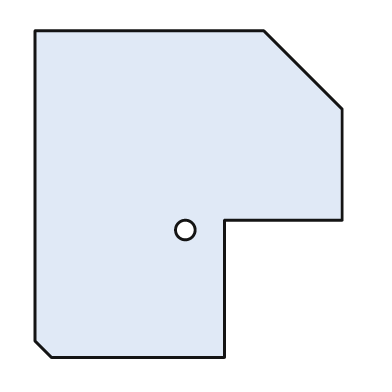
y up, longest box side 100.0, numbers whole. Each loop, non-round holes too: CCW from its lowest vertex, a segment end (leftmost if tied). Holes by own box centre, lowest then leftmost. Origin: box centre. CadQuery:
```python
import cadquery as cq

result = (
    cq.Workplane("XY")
    .moveTo(-42.0, -50.0)
    .lineTo(11.0, -50.0)
    .lineTo(11.0, -8.0)
    .lineTo(47.0, -8.0)
    .lineTo(47.0, 26.0)
    .lineTo(23.0, 50.0)
    .lineTo(-47.0, 50.0)
    .lineTo(-47.0, -45.0)
    .close()
    .moveTo(-1.0, -11.0)
    .circle(3.0)
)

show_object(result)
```